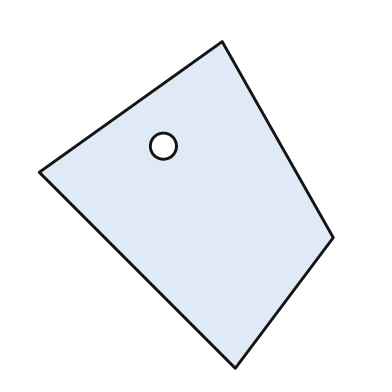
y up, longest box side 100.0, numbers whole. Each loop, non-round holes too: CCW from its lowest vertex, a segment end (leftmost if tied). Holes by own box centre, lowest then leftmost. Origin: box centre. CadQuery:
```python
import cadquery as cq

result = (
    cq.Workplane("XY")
    .moveTo(15.0, -50.0)
    .lineTo(45.0, -10.0)
    .lineTo(11.0, 50.0)
    .lineTo(-45.0, 10.0)
    .close()
    .moveTo(-7.0, 18.0)
    .circle(4.0)
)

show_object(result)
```